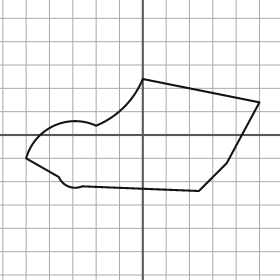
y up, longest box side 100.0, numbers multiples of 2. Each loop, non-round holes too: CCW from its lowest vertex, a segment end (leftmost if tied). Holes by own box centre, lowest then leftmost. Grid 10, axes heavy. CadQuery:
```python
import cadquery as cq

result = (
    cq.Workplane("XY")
    .moveTo(24.0, -24.0)
    .lineTo(36.0, -12.0)
    .lineTo(50.0, 14.0)
    .lineTo(0.0, 24.0)
    .threePointArc((-8.0, 12.0), (-20.0, 4.0))
    .threePointArc((-38.0, 4.0), (-50.0, -10.0))
    .lineTo(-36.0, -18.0)
    .threePointArc((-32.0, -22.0), (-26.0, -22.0))
    .close()
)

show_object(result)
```